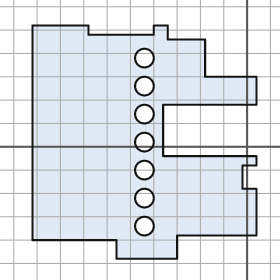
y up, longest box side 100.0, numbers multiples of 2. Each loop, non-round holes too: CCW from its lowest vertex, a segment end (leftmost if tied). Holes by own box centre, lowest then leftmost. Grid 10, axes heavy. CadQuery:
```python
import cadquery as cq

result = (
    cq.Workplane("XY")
    .moveTo(-56.0, -48.0)
    .lineTo(-30.0, -48.0)
    .lineTo(-30.0, -38.0)
    .lineTo(4.0, -38.0)
    .lineTo(4.0, -18.0)
    .lineTo(-2.0, -18.0)
    .lineTo(-2.0, -8.0)
    .lineTo(4.0, -8.0)
    .lineTo(4.0, -4.0)
    .lineTo(-36.0, -4.0)
    .lineTo(-36.0, 18.0)
    .lineTo(4.0, 18.0)
    .lineTo(4.0, 30.0)
    .lineTo(-18.0, 30.0)
    .lineTo(-18.0, 46.0)
    .lineTo(-34.0, 46.0)
    .lineTo(-34.0, 52.0)
    .lineTo(-40.0, 52.0)
    .lineTo(-40.0, 48.0)
    .lineTo(-68.0, 48.0)
    .lineTo(-68.0, 52.0)
    .lineTo(-92.0, 52.0)
    .lineTo(-92.0, -40.0)
    .lineTo(-56.0, -40.0)
    .close()
    .moveTo(-44.0, -34.0)
    .circle(4.0)
    .moveTo(-44.0, -22.0)
    .circle(4.0)
    .moveTo(-44.0, -10.0)
    .circle(4.0)
    .moveTo(-44.0, 2.0)
    .circle(4.0)
    .moveTo(-44.0, 14.0)
    .circle(4.0)
    .moveTo(-44.0, 26.0)
    .circle(4.0)
    .moveTo(-44.0, 38.0)
    .circle(4.0)
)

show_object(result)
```